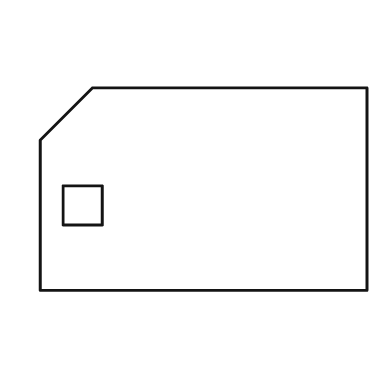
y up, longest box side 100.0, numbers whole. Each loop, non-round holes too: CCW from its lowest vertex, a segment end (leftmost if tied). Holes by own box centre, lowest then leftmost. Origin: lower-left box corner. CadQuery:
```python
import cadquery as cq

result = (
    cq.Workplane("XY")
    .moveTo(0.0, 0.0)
    .lineTo(100.0, 0.0)
    .lineTo(100.0, 62.0)
    .lineTo(16.0, 62.0)
    .lineTo(0.0, 46.0)
    .close()
    .moveTo(7.0, 20.0)
    .lineTo(19.0, 20.0)
    .lineTo(19.0, 32.0)
    .lineTo(7.0, 32.0)
    .close()
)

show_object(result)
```